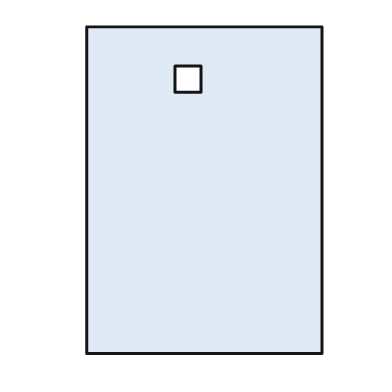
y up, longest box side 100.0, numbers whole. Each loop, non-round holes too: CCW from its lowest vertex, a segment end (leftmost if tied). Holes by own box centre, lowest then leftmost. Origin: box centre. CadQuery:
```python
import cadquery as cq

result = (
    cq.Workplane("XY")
    .moveTo(-36.0, -50.0)
    .lineTo(36.0, -50.0)
    .lineTo(36.0, 50.0)
    .lineTo(-36.0, 50.0)
    .close()
    .moveTo(-9.0, 30.0)
    .lineTo(-1.0, 30.0)
    .lineTo(-1.0, 38.0)
    .lineTo(-9.0, 38.0)
    .close()
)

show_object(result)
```